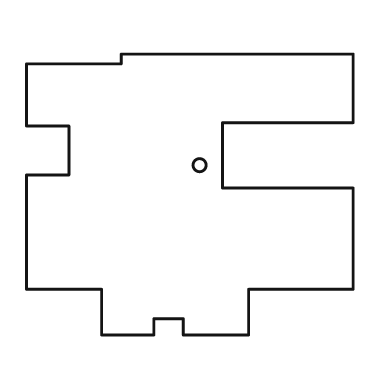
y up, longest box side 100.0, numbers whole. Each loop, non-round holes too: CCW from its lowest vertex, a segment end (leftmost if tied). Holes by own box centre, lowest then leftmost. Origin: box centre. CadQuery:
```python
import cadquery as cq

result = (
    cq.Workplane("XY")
    .moveTo(-27.0, -43.0)
    .lineTo(-11.0, -43.0)
    .lineTo(-11.0, -38.0)
    .lineTo(-2.0, -38.0)
    .lineTo(-2.0, -43.0)
    .lineTo(18.0, -43.0)
    .lineTo(18.0, -29.0)
    .lineTo(50.0, -29.0)
    .lineTo(50.0, 2.0)
    .lineTo(10.0, 2.0)
    .lineTo(10.0, 22.0)
    .lineTo(50.0, 22.0)
    .lineTo(50.0, 43.0)
    .lineTo(-21.0, 43.0)
    .lineTo(-21.0, 40.0)
    .lineTo(-50.0, 40.0)
    .lineTo(-50.0, 21.0)
    .lineTo(-37.0, 21.0)
    .lineTo(-37.0, 6.0)
    .lineTo(-50.0, 6.0)
    .lineTo(-50.0, -29.0)
    .lineTo(-27.0, -29.0)
    .close()
    .moveTo(3.0, 9.0)
    .circle(2.0)
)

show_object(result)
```